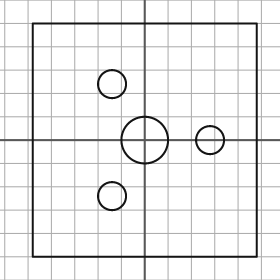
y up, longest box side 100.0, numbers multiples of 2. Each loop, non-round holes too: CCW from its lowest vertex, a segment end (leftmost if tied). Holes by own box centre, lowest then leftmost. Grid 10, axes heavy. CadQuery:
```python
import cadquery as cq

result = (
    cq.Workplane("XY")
    .moveTo(-48.0, -50.0)
    .lineTo(48.0, -50.0)
    .lineTo(48.0, 50.0)
    .lineTo(-48.0, 50.0)
    .close()
    .moveTo(-14.0, -24.0)
    .circle(6.0)
    .moveTo(0.0, 0.0)
    .circle(10.0)
    .moveTo(28.0, 0.0)
    .circle(6.0)
    .moveTo(-14.0, 24.0)
    .circle(6.0)
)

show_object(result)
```